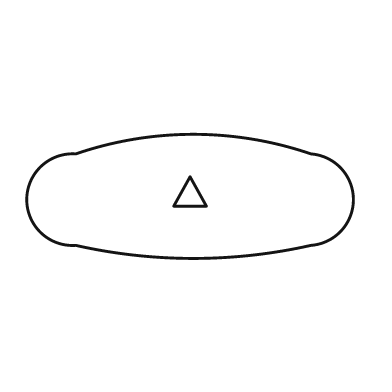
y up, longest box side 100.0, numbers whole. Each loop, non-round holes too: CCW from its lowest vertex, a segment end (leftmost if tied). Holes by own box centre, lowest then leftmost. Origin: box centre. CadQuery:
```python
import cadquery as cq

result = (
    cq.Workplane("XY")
    .moveTo(-35.0, -15.0)
    .threePointArc((1.0, -19.0), (37.0, -15.0))
    .threePointArc((50.0, -1.0), (37.0, 13.0))
    .threePointArc((1.0, 19.0), (-35.0, 13.0))
    .threePointArc((-50.0, -1.0), (-35.0, -15.0))
    .close()
    .moveTo(-5.0, -3.0)
    .lineTo(5.0, -3.0)
    .lineTo(0.0, 6.0)
    .close()
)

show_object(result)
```